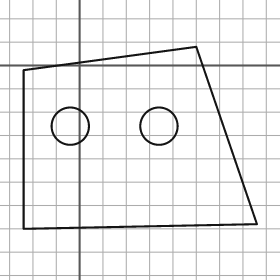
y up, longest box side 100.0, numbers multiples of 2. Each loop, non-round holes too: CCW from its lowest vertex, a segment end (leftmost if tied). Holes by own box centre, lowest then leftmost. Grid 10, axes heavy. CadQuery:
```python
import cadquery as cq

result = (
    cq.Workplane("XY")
    .moveTo(-24.0, -70.0)
    .lineTo(76.0, -68.0)
    .lineTo(50.0, 8.0)
    .lineTo(-24.0, -2.0)
    .close()
    .moveTo(-4.0, -26.0)
    .circle(8.0)
    .moveTo(34.0, -26.0)
    .circle(8.0)
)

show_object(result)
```